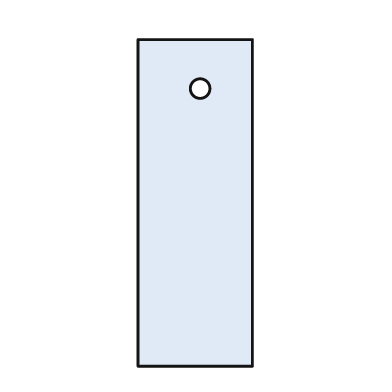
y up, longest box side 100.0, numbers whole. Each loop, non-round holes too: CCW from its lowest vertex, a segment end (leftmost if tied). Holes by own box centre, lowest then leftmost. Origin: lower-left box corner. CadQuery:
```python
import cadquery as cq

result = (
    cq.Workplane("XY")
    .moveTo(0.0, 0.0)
    .lineTo(35.0, 0.0)
    .lineTo(35.0, 100.0)
    .lineTo(0.0, 100.0)
    .close()
    .moveTo(19.0, 85.0)
    .circle(3.0)
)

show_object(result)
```